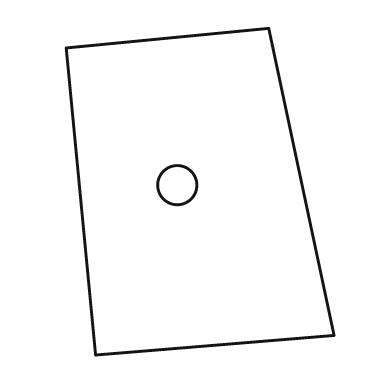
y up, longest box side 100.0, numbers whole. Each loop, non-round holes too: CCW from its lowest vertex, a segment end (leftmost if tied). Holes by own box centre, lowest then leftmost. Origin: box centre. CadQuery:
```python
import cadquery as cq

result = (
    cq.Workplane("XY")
    .moveTo(-32.0, -50.0)
    .lineTo(41.0, -44.0)
    .lineTo(21.0, 50.0)
    .lineTo(-41.0, 44.0)
    .close()
    .moveTo(-7.0, 2.0)
    .circle(6.0)
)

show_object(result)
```